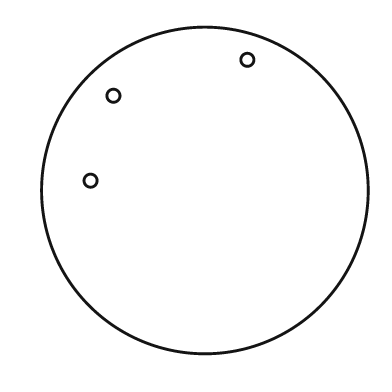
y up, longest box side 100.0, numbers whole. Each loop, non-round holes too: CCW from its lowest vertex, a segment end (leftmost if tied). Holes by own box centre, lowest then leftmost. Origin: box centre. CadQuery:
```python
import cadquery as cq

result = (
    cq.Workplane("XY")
    .moveTo(0.0, 0.0)
    .circle(50.0)
    .moveTo(-35.0, 3.0)
    .circle(2.0)
    .moveTo(-28.0, 29.0)
    .circle(2.0)
    .moveTo(13.0, 40.0)
    .circle(2.0)
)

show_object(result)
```